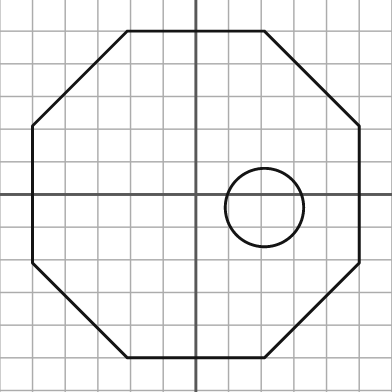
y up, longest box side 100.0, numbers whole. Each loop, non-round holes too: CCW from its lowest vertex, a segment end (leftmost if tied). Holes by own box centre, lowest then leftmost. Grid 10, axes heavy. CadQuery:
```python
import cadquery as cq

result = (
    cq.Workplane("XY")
    .moveTo(-21.0, -50.0)
    .lineTo(21.0, -50.0)
    .lineTo(50.0, -21.0)
    .lineTo(50.0, 21.0)
    .lineTo(21.0, 50.0)
    .lineTo(-21.0, 50.0)
    .lineTo(-50.0, 21.0)
    .lineTo(-50.0, -21.0)
    .close()
    .moveTo(21.0, -4.0)
    .circle(12.0)
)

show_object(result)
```